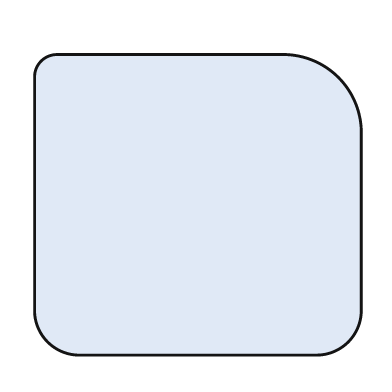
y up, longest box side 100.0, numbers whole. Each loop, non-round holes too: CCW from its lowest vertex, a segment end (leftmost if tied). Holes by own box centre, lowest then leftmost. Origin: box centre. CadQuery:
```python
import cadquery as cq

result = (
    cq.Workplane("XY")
    .moveTo(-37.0, -46.0)
    .lineTo(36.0, -46.0)
    .threePointArc((46.0, -42.0), (50.0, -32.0))
    .lineTo(50.0, 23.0)
    .threePointArc((43.0, 39.0), (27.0, 46.0))
    .lineTo(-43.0, 46.0)
    .threePointArc((-48.0, 44.0), (-50.0, 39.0))
    .lineTo(-50.0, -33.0)
    .threePointArc((-46.0, -42.0), (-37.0, -46.0))
    .close()
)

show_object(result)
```